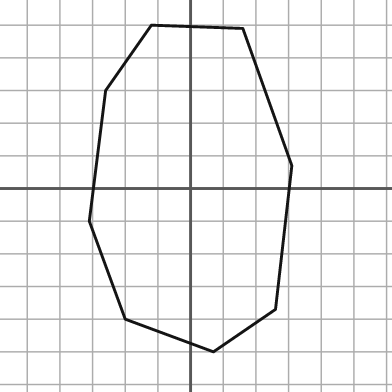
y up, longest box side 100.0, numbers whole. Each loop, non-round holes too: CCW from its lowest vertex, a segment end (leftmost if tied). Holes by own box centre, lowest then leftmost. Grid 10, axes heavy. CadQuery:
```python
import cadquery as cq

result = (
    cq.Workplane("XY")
    .moveTo(7.0, -50.0)
    .lineTo(26.0, -37.0)
    .lineTo(31.0, 7.0)
    .lineTo(16.0, 49.0)
    .lineTo(-12.0, 50.0)
    .lineTo(-26.0, 30.0)
    .lineTo(-31.0, -10.0)
    .lineTo(-20.0, -40.0)
    .close()
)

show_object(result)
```